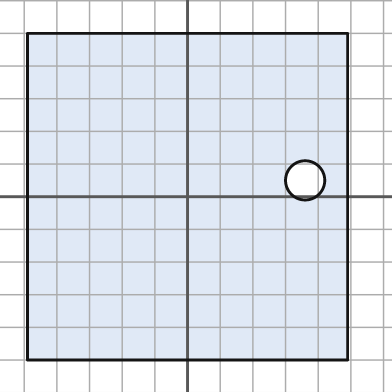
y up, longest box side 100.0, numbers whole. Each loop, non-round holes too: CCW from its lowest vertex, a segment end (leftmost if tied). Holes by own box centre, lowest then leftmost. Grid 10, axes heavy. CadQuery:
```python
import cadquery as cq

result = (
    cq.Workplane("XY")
    .moveTo(-49.0, -50.0)
    .lineTo(49.0, -50.0)
    .lineTo(49.0, 50.0)
    .lineTo(-49.0, 50.0)
    .close()
    .moveTo(36.0, 5.0)
    .circle(6.0)
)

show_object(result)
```